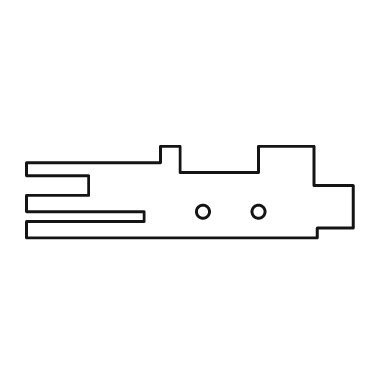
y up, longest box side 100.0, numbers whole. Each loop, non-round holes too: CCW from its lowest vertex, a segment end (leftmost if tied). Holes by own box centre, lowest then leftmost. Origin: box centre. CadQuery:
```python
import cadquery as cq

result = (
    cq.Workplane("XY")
    .moveTo(-50.0, -14.0)
    .lineTo(39.0, -14.0)
    .lineTo(39.0, -11.0)
    .lineTo(50.0, -11.0)
    .lineTo(50.0, 2.0)
    .lineTo(38.0, 2.0)
    .lineTo(38.0, 14.0)
    .lineTo(21.0, 14.0)
    .lineTo(21.0, 6.0)
    .lineTo(-3.0, 6.0)
    .lineTo(-3.0, 14.0)
    .lineTo(-9.0, 14.0)
    .lineTo(-9.0, 9.0)
    .lineTo(-50.0, 9.0)
    .lineTo(-50.0, 5.0)
    .lineTo(-31.0, 5.0)
    .lineTo(-31.0, -1.0)
    .lineTo(-50.0, -1.0)
    .lineTo(-50.0, -6.0)
    .lineTo(-14.0, -6.0)
    .lineTo(-14.0, -9.0)
    .lineTo(-50.0, -9.0)
    .close()
    .moveTo(4.0, -6.0)
    .circle(2.0)
    .moveTo(21.0, -6.0)
    .circle(2.0)
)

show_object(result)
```